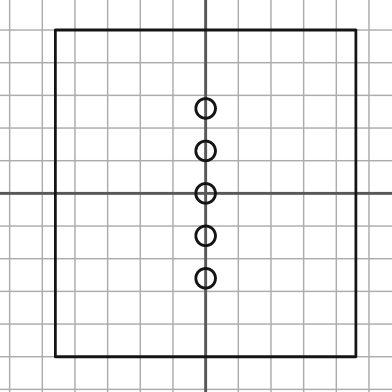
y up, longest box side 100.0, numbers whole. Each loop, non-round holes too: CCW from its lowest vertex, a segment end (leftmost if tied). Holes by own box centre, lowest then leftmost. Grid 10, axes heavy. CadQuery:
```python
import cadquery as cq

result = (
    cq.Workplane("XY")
    .moveTo(-46.0, -50.0)
    .lineTo(46.0, -50.0)
    .lineTo(46.0, 50.0)
    .lineTo(-46.0, 50.0)
    .close()
    .moveTo(0.0, -26.0)
    .circle(3.0)
    .moveTo(0.0, -13.0)
    .circle(3.0)
    .moveTo(0.0, 0.0)
    .circle(3.0)
    .moveTo(0.0, 13.0)
    .circle(3.0)
    .moveTo(0.0, 26.0)
    .circle(3.0)
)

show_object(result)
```